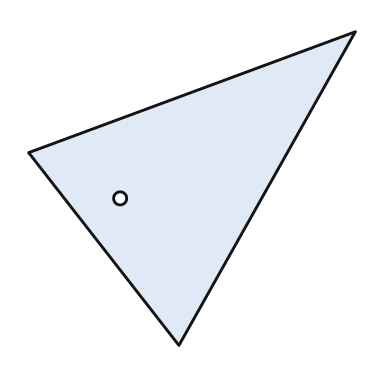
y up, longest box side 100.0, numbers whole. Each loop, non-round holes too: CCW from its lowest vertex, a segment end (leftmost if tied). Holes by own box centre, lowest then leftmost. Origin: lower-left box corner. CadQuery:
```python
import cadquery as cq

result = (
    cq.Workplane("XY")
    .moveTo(46.0, 0.0)
    .lineTo(100.0, 96.0)
    .lineTo(0.0, 59.0)
    .close()
    .moveTo(28.0, 45.0)
    .circle(2.0)
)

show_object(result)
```